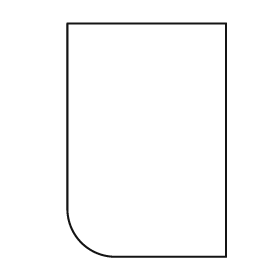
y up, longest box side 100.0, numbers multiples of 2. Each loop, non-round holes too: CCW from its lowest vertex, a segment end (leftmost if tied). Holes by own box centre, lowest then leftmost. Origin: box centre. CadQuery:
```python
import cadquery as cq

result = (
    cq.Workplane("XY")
    .moveTo(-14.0, -50.0)
    .lineTo(34.0, -50.0)
    .lineTo(34.0, 50.0)
    .lineTo(-34.0, 50.0)
    .lineTo(-34.0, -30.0)
    .threePointArc((-28.0, -44.0), (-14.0, -50.0))
    .close()
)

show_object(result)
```